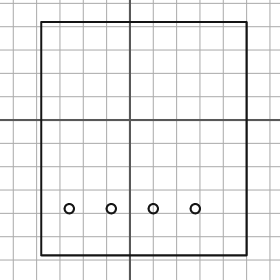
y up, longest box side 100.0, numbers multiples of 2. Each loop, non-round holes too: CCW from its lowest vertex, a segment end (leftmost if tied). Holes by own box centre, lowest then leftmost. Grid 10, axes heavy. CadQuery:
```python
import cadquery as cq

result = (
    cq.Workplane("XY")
    .moveTo(-38.0, -58.0)
    .lineTo(50.0, -58.0)
    .lineTo(50.0, 42.0)
    .lineTo(-38.0, 42.0)
    .close()
    .moveTo(-26.0, -38.0)
    .circle(2.0)
    .moveTo(-8.0, -38.0)
    .circle(2.0)
    .moveTo(10.0, -38.0)
    .circle(2.0)
    .moveTo(28.0, -38.0)
    .circle(2.0)
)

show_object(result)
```